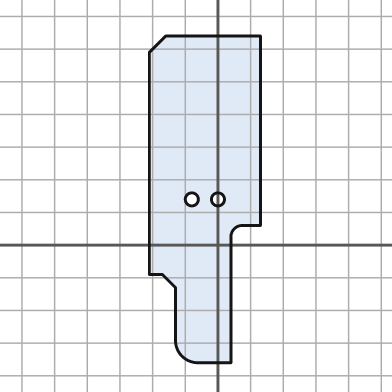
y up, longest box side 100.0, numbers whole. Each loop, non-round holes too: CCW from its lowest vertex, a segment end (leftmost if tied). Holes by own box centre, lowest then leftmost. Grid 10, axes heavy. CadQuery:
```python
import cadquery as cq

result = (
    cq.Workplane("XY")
    .moveTo(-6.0, -36.0)
    .lineTo(4.0, -36.0)
    .lineTo(4.0, 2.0)
    .threePointArc((5.0, 5.0), (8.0, 6.0))
    .lineTo(13.0, 6.0)
    .lineTo(13.0, 64.0)
    .lineTo(-16.0, 64.0)
    .lineTo(-21.0, 59.0)
    .lineTo(-21.0, -9.0)
    .lineTo(-17.0, -9.0)
    .lineTo(-13.0, -13.0)
    .lineTo(-13.0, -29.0)
    .threePointArc((-11.0, -34.0), (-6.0, -36.0))
    .close()
    .moveTo(-8.0, 14.0)
    .circle(2.0)
    .moveTo(0.0, 14.0)
    .circle(2.0)
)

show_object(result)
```